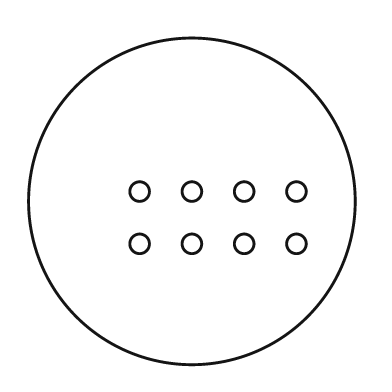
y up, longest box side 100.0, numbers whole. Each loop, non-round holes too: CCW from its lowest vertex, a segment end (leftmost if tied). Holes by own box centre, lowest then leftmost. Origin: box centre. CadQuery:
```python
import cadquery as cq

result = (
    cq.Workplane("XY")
    .moveTo(0.0, 0.0)
    .circle(50.0)
    .moveTo(-16.0, -13.0)
    .circle(3.0)
    .moveTo(0.0, -13.0)
    .circle(3.0)
    .moveTo(16.0, -13.0)
    .circle(3.0)
    .moveTo(32.0, -13.0)
    .circle(3.0)
    .moveTo(-16.0, 3.0)
    .circle(3.0)
    .moveTo(0.0, 3.0)
    .circle(3.0)
    .moveTo(16.0, 3.0)
    .circle(3.0)
    .moveTo(32.0, 3.0)
    .circle(3.0)
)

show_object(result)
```